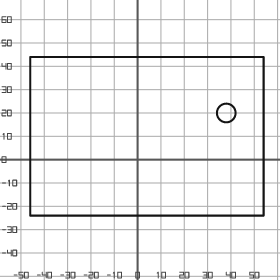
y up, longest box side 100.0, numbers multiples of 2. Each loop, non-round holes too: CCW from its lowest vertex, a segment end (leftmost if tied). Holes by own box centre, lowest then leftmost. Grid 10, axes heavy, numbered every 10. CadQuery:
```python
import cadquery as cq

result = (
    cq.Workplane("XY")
    .moveTo(-46.0, -24.0)
    .lineTo(54.0, -24.0)
    .lineTo(54.0, 44.0)
    .lineTo(-46.0, 44.0)
    .close()
    .moveTo(38.0, 20.0)
    .circle(4.0)
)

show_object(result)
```